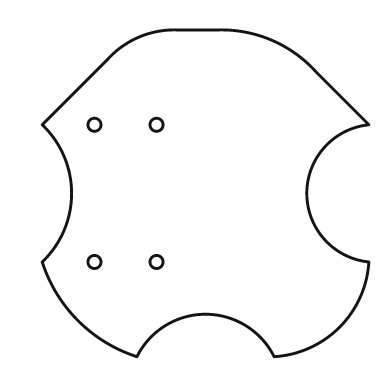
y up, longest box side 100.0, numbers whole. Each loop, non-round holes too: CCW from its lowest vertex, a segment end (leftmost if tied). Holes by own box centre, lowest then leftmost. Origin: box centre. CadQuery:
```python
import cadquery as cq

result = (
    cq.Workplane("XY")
    .moveTo(-21.0, -50.0)
    .threePointArc((0.0, -37.0), (21.0, -50.0))
    .threePointArc((41.0, -41.0), (50.0, -21.0))
    .threePointArc((31.0, 0.0), (50.0, 21.0))
    .lineTo(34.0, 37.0)
    .threePointArc((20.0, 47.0), (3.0, 50.0))
    .lineTo(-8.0, 50.0)
    .threePointArc((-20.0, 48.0), (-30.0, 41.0))
    .lineTo(-50.0, 21.0)
    .threePointArc((-41.0, 0.0), (-50.0, -21.0))
    .threePointArc((-39.0, -39.0), (-21.0, -50.0))
    .close()
    .moveTo(-34.0, -21.0)
    .circle(2.0)
    .moveTo(-15.0, -21.0)
    .circle(2.0)
    .moveTo(-34.0, 21.0)
    .circle(2.0)
    .moveTo(-15.0, 21.0)
    .circle(2.0)
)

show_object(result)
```